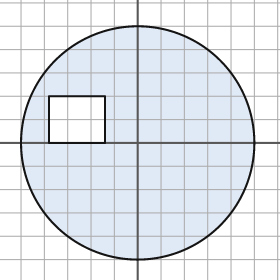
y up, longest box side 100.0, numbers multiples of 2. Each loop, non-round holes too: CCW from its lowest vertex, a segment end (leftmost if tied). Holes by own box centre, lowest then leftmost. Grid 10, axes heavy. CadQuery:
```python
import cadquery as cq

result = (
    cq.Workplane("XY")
    .moveTo(0.0, 0.0)
    .circle(50.0)
    .moveTo(-38.0, 0.0)
    .lineTo(-14.0, 0.0)
    .lineTo(-14.0, 20.0)
    .lineTo(-38.0, 20.0)
    .close()
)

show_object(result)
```